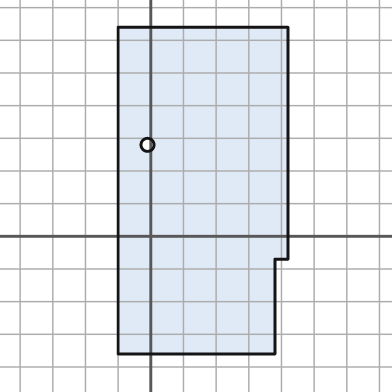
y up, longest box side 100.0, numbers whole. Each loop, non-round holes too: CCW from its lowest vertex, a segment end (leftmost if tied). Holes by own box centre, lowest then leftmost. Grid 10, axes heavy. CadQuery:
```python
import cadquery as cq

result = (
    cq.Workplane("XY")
    .moveTo(-10.0, -36.0)
    .lineTo(38.0, -36.0)
    .lineTo(38.0, -7.0)
    .lineTo(42.0, -7.0)
    .lineTo(42.0, 64.0)
    .lineTo(-10.0, 64.0)
    .close()
    .moveTo(-1.0, 28.0)
    .circle(2.0)
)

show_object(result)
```